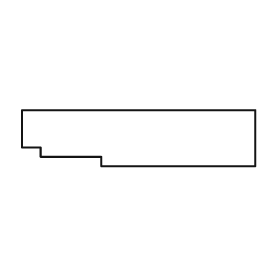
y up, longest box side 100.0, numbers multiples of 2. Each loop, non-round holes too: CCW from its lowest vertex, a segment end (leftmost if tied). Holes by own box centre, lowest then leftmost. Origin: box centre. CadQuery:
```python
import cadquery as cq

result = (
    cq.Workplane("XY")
    .moveTo(-16.0, -12.0)
    .lineTo(50.0, -12.0)
    .lineTo(50.0, 12.0)
    .lineTo(-50.0, 12.0)
    .lineTo(-50.0, -4.0)
    .lineTo(-42.0, -4.0)
    .lineTo(-42.0, -8.0)
    .lineTo(-16.0, -8.0)
    .close()
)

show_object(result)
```